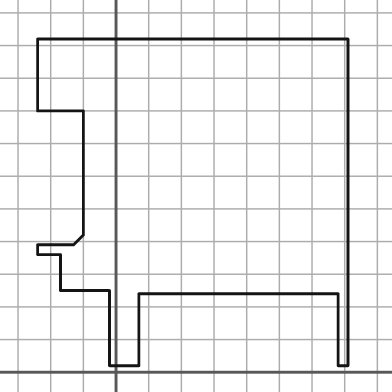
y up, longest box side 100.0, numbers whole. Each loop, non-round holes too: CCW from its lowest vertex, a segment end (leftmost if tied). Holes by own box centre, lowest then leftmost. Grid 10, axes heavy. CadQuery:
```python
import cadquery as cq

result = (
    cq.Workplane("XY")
    .moveTo(-2.0, 2.0)
    .lineTo(7.0, 2.0)
    .lineTo(7.0, 24.0)
    .lineTo(68.0, 24.0)
    .lineTo(68.0, 2.0)
    .lineTo(71.0, 2.0)
    .lineTo(71.0, 102.0)
    .lineTo(-24.0, 102.0)
    .lineTo(-24.0, 80.0)
    .lineTo(-10.0, 80.0)
    .lineTo(-10.0, 42.0)
    .lineTo(-13.0, 39.0)
    .lineTo(-24.0, 39.0)
    .lineTo(-24.0, 36.0)
    .lineTo(-17.0, 36.0)
    .lineTo(-17.0, 25.0)
    .lineTo(-2.0, 25.0)
    .close()
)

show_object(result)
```